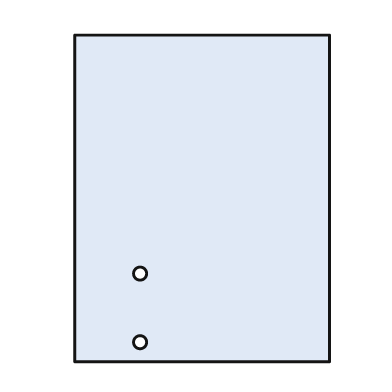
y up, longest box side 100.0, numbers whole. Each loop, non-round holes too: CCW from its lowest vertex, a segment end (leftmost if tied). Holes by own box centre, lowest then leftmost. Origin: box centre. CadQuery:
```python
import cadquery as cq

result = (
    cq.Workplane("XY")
    .moveTo(-39.0, -50.0)
    .lineTo(39.0, -50.0)
    .lineTo(39.0, 50.0)
    .lineTo(-39.0, 50.0)
    .close()
    .moveTo(-19.0, -44.0)
    .circle(2.0)
    .moveTo(-19.0, -23.0)
    .circle(2.0)
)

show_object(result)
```